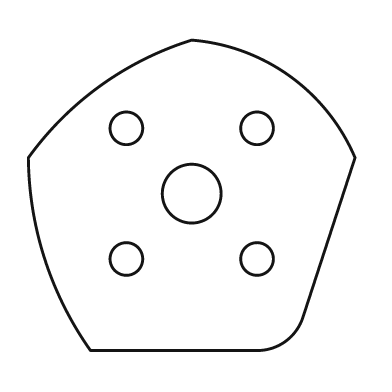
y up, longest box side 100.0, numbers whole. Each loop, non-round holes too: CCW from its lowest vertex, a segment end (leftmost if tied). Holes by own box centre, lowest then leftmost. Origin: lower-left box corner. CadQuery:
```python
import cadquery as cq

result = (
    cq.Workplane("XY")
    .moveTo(19.0, 0.0)
    .lineTo(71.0, 0.0)
    .threePointArc((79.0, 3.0), (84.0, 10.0))
    .lineTo(100.0, 59.0)
    .threePointArc((80.0, 84.0), (50.0, 95.0))
    .threePointArc((22.0, 81.0), (0.0, 59.0))
    .threePointArc((5.0, 28.0), (19.0, 0.0))
    .close()
    .moveTo(30.0, 28.0)
    .circle(5.0)
    .moveTo(70.0, 28.0)
    .circle(5.0)
    .moveTo(50.0, 48.0)
    .circle(9.0)
    .moveTo(30.0, 68.0)
    .circle(5.0)
    .moveTo(70.0, 68.0)
    .circle(5.0)
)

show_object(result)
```